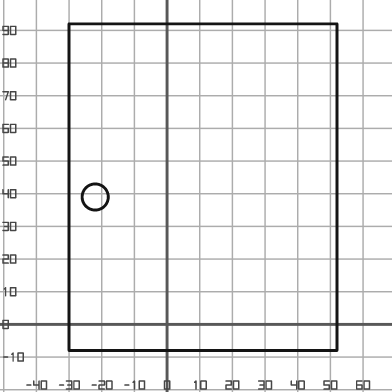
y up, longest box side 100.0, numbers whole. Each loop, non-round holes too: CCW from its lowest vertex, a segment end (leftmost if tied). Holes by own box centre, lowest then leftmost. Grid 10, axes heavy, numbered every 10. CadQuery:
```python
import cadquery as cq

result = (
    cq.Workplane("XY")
    .moveTo(-30.0, -8.0)
    .lineTo(52.0, -8.0)
    .lineTo(52.0, 92.0)
    .lineTo(-30.0, 92.0)
    .close()
    .moveTo(-22.0, 39.0)
    .circle(4.0)
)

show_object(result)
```